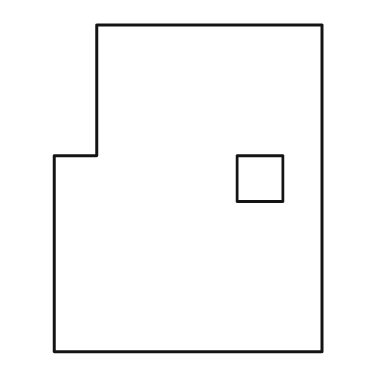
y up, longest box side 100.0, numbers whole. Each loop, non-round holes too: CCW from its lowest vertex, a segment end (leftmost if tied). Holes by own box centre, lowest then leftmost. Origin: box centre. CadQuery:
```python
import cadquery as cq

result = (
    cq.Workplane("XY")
    .moveTo(-41.0, -50.0)
    .lineTo(41.0, -50.0)
    .lineTo(41.0, 50.0)
    .lineTo(-28.0, 50.0)
    .lineTo(-28.0, 10.0)
    .lineTo(-41.0, 10.0)
    .close()
    .moveTo(15.0, -4.0)
    .lineTo(29.0, -4.0)
    .lineTo(29.0, 10.0)
    .lineTo(15.0, 10.0)
    .close()
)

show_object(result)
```